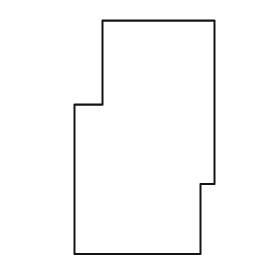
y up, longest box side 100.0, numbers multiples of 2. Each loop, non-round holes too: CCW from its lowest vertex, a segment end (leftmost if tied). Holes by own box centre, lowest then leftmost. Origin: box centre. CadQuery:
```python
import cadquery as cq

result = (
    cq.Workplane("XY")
    .moveTo(-30.0, -50.0)
    .lineTo(24.0, -50.0)
    .lineTo(24.0, -20.0)
    .lineTo(30.0, -20.0)
    .lineTo(30.0, 50.0)
    .lineTo(-18.0, 50.0)
    .lineTo(-18.0, 14.0)
    .lineTo(-30.0, 14.0)
    .close()
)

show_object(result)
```